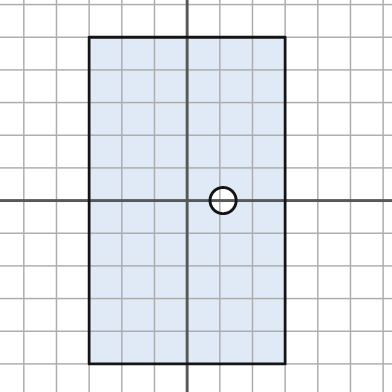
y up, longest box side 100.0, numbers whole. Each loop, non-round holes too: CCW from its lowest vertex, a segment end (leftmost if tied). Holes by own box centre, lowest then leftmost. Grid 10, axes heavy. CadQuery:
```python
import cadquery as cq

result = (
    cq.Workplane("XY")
    .moveTo(-30.0, -50.0)
    .lineTo(30.0, -50.0)
    .lineTo(30.0, 50.0)
    .lineTo(-30.0, 50.0)
    .close()
    .moveTo(11.0, 0.0)
    .circle(4.0)
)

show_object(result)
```